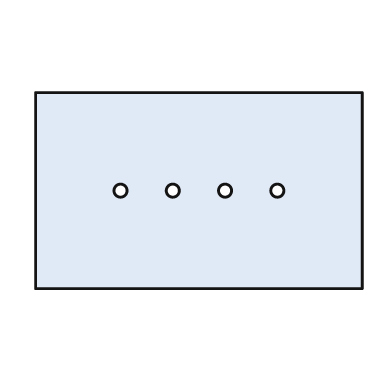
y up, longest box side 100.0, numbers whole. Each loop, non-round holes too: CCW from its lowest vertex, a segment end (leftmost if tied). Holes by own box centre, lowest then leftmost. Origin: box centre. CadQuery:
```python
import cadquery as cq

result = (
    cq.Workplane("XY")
    .moveTo(-50.0, -30.0)
    .lineTo(50.0, -30.0)
    .lineTo(50.0, 30.0)
    .lineTo(-50.0, 30.0)
    .close()
    .moveTo(-24.0, 0.0)
    .circle(2.0)
    .moveTo(-8.0, 0.0)
    .circle(2.0)
    .moveTo(8.0, 0.0)
    .circle(2.0)
    .moveTo(24.0, 0.0)
    .circle(2.0)
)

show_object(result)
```